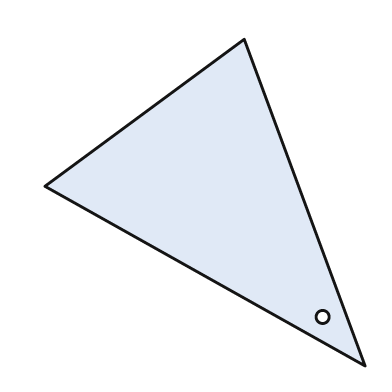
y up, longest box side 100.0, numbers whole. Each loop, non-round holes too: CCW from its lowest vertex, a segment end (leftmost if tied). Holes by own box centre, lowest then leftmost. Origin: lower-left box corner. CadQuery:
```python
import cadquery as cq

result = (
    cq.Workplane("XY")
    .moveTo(98.0, 0.0)
    .lineTo(61.0, 100.0)
    .lineTo(0.0, 55.0)
    .close()
    .moveTo(85.0, 15.0)
    .circle(2.0)
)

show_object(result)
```